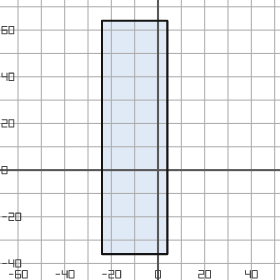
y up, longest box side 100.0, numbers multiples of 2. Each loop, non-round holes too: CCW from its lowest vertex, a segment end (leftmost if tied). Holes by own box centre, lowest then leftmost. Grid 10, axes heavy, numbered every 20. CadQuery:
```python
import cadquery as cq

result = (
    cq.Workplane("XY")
    .moveTo(-24.0, -36.0)
    .lineTo(4.0, -36.0)
    .lineTo(4.0, 64.0)
    .lineTo(-24.0, 64.0)
    .close()
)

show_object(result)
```